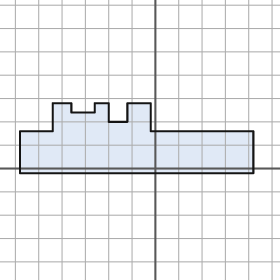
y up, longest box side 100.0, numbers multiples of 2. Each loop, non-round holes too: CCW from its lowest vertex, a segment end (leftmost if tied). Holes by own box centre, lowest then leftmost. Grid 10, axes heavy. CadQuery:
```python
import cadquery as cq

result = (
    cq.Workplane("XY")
    .moveTo(-58.0, -2.0)
    .lineTo(42.0, -2.0)
    .lineTo(42.0, 16.0)
    .lineTo(-2.0, 16.0)
    .lineTo(-2.0, 28.0)
    .lineTo(-12.0, 28.0)
    .lineTo(-12.0, 20.0)
    .lineTo(-20.0, 20.0)
    .lineTo(-20.0, 28.0)
    .lineTo(-26.0, 28.0)
    .lineTo(-26.0, 24.0)
    .lineTo(-36.0, 24.0)
    .lineTo(-36.0, 28.0)
    .lineTo(-44.0, 28.0)
    .lineTo(-44.0, 16.0)
    .lineTo(-58.0, 16.0)
    .close()
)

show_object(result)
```